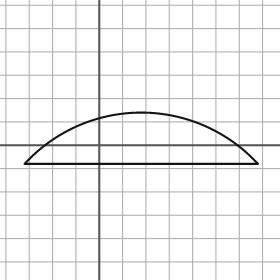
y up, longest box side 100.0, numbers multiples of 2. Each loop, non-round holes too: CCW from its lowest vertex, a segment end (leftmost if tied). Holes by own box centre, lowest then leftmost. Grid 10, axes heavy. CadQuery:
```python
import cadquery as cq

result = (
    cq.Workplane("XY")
    .moveTo(-32.0, -8.0)
    .lineTo(68.0, -8.0)
    .threePointArc((18.0, 14.0), (-32.0, -8.0))
    .close()
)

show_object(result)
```